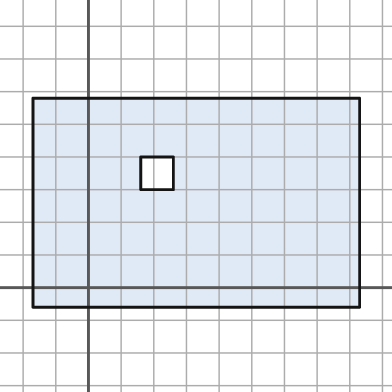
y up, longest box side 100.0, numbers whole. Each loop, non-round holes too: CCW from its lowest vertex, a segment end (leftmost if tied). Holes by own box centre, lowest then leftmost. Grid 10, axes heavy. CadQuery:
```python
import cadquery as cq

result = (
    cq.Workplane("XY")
    .moveTo(-17.0, -6.0)
    .lineTo(83.0, -6.0)
    .lineTo(83.0, 58.0)
    .lineTo(-17.0, 58.0)
    .close()
    .moveTo(16.0, 30.0)
    .lineTo(26.0, 30.0)
    .lineTo(26.0, 40.0)
    .lineTo(16.0, 40.0)
    .close()
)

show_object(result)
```